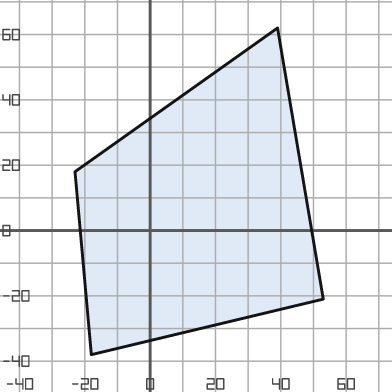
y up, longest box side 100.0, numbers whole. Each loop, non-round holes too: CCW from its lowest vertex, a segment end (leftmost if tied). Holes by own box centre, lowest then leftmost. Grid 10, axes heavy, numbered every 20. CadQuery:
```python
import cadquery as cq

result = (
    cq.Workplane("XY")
    .moveTo(-18.0, -38.0)
    .lineTo(53.0, -21.0)
    .lineTo(39.0, 62.0)
    .lineTo(-23.0, 18.0)
    .close()
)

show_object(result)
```